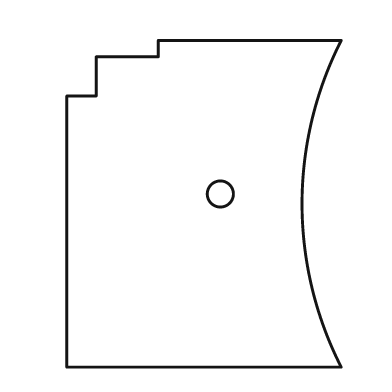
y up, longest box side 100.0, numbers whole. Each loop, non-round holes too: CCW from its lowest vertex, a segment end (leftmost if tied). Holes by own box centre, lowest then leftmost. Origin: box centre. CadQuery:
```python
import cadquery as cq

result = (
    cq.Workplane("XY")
    .moveTo(-42.0, -50.0)
    .lineTo(42.0, -50.0)
    .threePointArc((30.0, 0.0), (42.0, 50.0))
    .lineTo(-14.0, 50.0)
    .lineTo(-14.0, 45.0)
    .lineTo(-33.0, 45.0)
    .lineTo(-33.0, 33.0)
    .lineTo(-42.0, 33.0)
    .close()
    .moveTo(5.0, 3.0)
    .circle(4.0)
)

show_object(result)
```